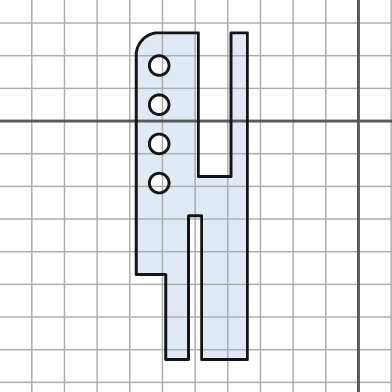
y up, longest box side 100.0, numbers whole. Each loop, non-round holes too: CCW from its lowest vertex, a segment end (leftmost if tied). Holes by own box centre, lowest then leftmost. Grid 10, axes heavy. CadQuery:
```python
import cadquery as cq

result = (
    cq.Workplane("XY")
    .moveTo(-59.0, -73.0)
    .lineTo(-52.0, -73.0)
    .lineTo(-52.0, -29.0)
    .lineTo(-48.0, -29.0)
    .lineTo(-48.0, -73.0)
    .lineTo(-34.0, -73.0)
    .lineTo(-34.0, 27.0)
    .lineTo(-39.0, 27.0)
    .lineTo(-39.0, -17.0)
    .lineTo(-49.0, -17.0)
    .lineTo(-49.0, 27.0)
    .lineTo(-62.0, 27.0)
    .threePointArc((-66.0, 25.0), (-68.0, 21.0))
    .lineTo(-68.0, -47.0)
    .lineTo(-59.0, -47.0)
    .close()
    .moveTo(-61.0, -19.0)
    .circle(3.0)
    .moveTo(-61.0, -7.0)
    .circle(3.0)
    .moveTo(-61.0, 5.0)
    .circle(3.0)
    .moveTo(-61.0, 17.0)
    .circle(3.0)
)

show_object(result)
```